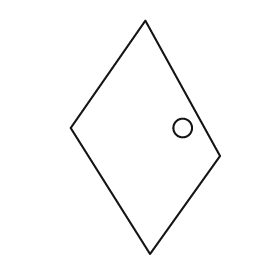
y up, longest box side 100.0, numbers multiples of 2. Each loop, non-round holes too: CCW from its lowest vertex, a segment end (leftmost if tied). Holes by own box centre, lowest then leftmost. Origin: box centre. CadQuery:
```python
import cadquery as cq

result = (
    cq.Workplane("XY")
    .moveTo(2.0, -50.0)
    .lineTo(32.0, -8.0)
    .lineTo(0.0, 50.0)
    .lineTo(-32.0, 4.0)
    .close()
    .moveTo(16.0, 4.0)
    .circle(4.0)
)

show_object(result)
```